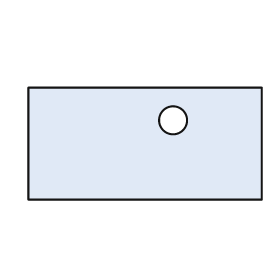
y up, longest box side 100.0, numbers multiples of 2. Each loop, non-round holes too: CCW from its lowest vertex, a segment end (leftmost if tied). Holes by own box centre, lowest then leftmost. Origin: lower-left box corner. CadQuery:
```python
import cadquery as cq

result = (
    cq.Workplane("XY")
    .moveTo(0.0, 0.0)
    .lineTo(100.0, 0.0)
    .lineTo(100.0, 48.0)
    .lineTo(0.0, 48.0)
    .close()
    .moveTo(62.0, 34.0)
    .circle(6.0)
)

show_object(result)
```